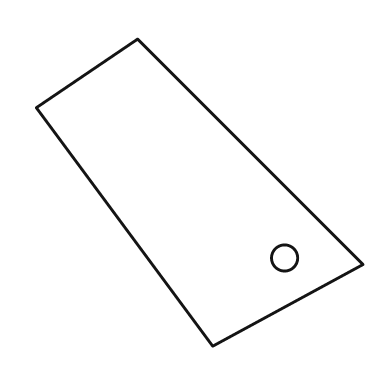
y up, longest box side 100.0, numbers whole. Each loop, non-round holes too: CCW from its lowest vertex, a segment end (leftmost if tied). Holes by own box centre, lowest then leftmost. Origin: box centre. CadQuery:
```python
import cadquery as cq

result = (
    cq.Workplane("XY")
    .moveTo(4.0, -47.0)
    .lineTo(50.0, -22.0)
    .lineTo(-19.0, 47.0)
    .lineTo(-50.0, 26.0)
    .close()
    .moveTo(26.0, -20.0)
    .circle(4.0)
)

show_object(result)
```